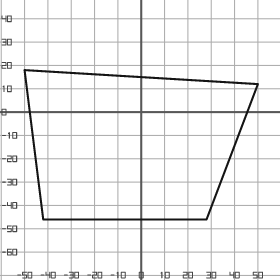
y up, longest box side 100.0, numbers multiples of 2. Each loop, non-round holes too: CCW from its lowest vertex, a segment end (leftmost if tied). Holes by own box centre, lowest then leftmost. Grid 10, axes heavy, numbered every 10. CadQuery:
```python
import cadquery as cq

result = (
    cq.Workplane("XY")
    .moveTo(-42.0, -46.0)
    .lineTo(28.0, -46.0)
    .lineTo(50.0, 12.0)
    .lineTo(-50.0, 18.0)
    .close()
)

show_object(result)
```